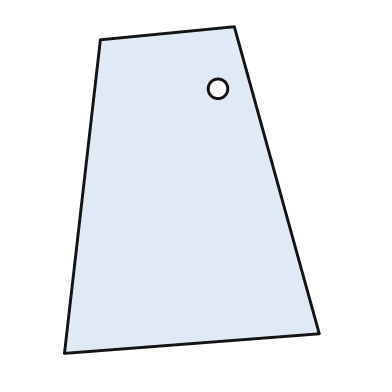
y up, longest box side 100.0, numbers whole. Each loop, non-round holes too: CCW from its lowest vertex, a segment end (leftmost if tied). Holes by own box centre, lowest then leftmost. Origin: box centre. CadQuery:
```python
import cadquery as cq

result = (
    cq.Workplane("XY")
    .moveTo(-39.0, -50.0)
    .lineTo(39.0, -44.0)
    .lineTo(13.0, 50.0)
    .lineTo(-28.0, 46.0)
    .close()
    .moveTo(8.0, 31.0)
    .circle(3.0)
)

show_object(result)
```